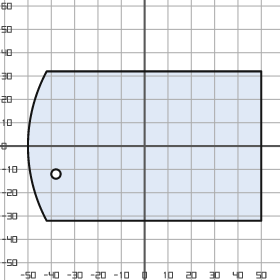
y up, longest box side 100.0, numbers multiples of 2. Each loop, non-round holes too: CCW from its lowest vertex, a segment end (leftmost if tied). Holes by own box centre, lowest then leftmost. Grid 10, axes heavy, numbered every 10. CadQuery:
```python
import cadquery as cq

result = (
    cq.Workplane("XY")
    .moveTo(-42.0, -32.0)
    .lineTo(50.0, -32.0)
    .lineTo(50.0, 32.0)
    .lineTo(-42.0, 32.0)
    .threePointArc((-50.0, 0.0), (-42.0, -32.0))
    .close()
    .moveTo(-38.0, -12.0)
    .circle(2.0)
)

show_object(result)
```